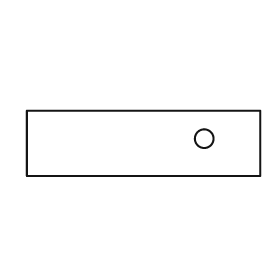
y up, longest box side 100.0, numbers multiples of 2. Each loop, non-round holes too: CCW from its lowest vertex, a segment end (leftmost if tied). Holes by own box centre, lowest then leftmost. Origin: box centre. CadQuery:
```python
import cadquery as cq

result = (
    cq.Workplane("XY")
    .moveTo(-50.0, -14.0)
    .lineTo(50.0, -14.0)
    .lineTo(50.0, 14.0)
    .lineTo(-50.0, 14.0)
    .close()
    .moveTo(26.0, 2.0)
    .circle(4.0)
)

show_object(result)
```